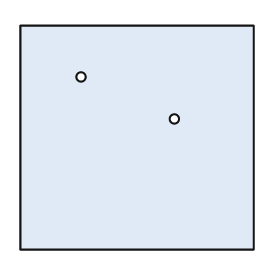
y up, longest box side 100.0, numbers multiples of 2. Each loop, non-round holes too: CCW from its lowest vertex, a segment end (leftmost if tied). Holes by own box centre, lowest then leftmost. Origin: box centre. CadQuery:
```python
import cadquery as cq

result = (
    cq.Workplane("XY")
    .moveTo(-50.0, -48.0)
    .lineTo(50.0, -48.0)
    .lineTo(50.0, 48.0)
    .lineTo(-50.0, 48.0)
    .close()
    .moveTo(16.0, 8.0)
    .circle(2.0)
    .moveTo(-24.0, 26.0)
    .circle(2.0)
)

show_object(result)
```